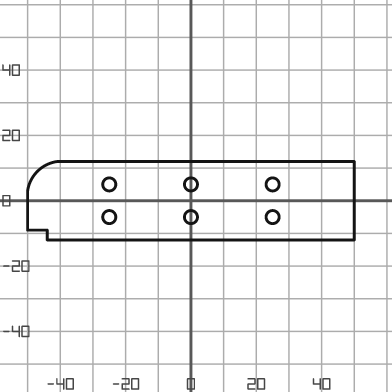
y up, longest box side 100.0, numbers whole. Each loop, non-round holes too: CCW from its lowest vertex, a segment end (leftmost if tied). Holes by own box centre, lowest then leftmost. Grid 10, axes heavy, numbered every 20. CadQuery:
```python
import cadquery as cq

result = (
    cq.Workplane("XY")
    .moveTo(-44.0, -12.0)
    .lineTo(50.0, -12.0)
    .lineTo(50.0, 12.0)
    .lineTo(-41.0, 12.0)
    .threePointArc((-47.0, 9.0), (-50.0, 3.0))
    .lineTo(-50.0, -9.0)
    .lineTo(-44.0, -9.0)
    .close()
    .moveTo(-25.0, -5.0)
    .circle(2.0)
    .moveTo(0.0, -5.0)
    .circle(2.0)
    .moveTo(25.0, -5.0)
    .circle(2.0)
    .moveTo(-25.0, 5.0)
    .circle(2.0)
    .moveTo(0.0, 5.0)
    .circle(2.0)
    .moveTo(25.0, 5.0)
    .circle(2.0)
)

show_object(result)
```